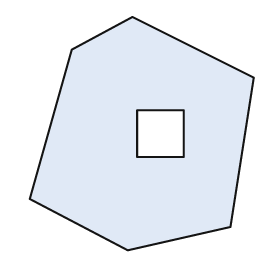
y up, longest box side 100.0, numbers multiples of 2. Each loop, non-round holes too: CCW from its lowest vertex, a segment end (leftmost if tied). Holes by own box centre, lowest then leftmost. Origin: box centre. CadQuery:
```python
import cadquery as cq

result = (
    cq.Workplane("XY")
    .moveTo(-6.0, -50.0)
    .lineTo(38.0, -40.0)
    .lineTo(48.0, 24.0)
    .lineTo(-4.0, 50.0)
    .lineTo(-30.0, 36.0)
    .lineTo(-48.0, -28.0)
    .close()
    .moveTo(-2.0, -10.0)
    .lineTo(18.0, -10.0)
    .lineTo(18.0, 10.0)
    .lineTo(-2.0, 10.0)
    .close()
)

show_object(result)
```